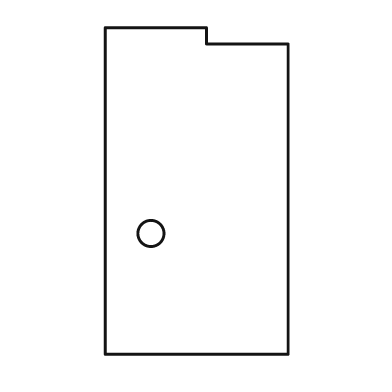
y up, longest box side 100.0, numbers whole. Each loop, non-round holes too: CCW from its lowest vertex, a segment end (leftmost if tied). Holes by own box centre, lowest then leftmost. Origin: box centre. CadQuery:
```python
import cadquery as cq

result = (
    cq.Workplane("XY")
    .moveTo(-28.0, -50.0)
    .lineTo(28.0, -50.0)
    .lineTo(28.0, 45.0)
    .lineTo(3.0, 45.0)
    .lineTo(3.0, 50.0)
    .lineTo(-28.0, 50.0)
    .close()
    .moveTo(-14.0, -13.0)
    .circle(4.0)
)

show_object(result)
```